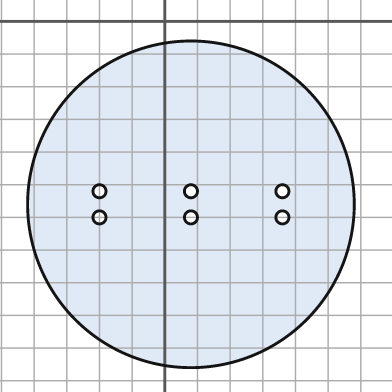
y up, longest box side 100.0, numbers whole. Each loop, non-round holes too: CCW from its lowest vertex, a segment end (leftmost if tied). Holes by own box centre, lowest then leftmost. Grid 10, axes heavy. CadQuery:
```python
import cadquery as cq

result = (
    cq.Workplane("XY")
    .moveTo(8.0, -56.0)
    .circle(50.0)
    .moveTo(-20.0, -60.0)
    .circle(2.0)
    .moveTo(8.0, -60.0)
    .circle(2.0)
    .moveTo(36.0, -60.0)
    .circle(2.0)
    .moveTo(-20.0, -52.0)
    .circle(2.0)
    .moveTo(8.0, -52.0)
    .circle(2.0)
    .moveTo(36.0, -52.0)
    .circle(2.0)
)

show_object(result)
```